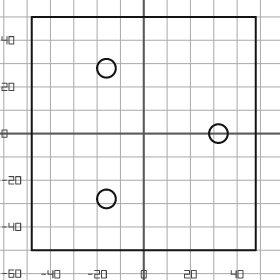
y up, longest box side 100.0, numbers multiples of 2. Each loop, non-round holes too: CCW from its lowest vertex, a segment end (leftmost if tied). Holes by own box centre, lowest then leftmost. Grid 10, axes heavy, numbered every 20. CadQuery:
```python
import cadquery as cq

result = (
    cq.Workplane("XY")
    .moveTo(-48.0, -50.0)
    .lineTo(48.0, -50.0)
    .lineTo(48.0, 50.0)
    .lineTo(-48.0, 50.0)
    .close()
    .moveTo(-16.0, -28.0)
    .circle(4.0)
    .moveTo(32.0, 0.0)
    .circle(4.0)
    .moveTo(-16.0, 28.0)
    .circle(4.0)
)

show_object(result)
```